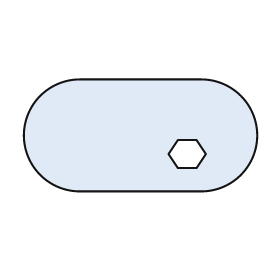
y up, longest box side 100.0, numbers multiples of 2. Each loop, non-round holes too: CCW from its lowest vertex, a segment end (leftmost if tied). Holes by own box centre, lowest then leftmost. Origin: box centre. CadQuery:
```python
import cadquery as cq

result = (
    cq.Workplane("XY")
    .moveTo(-26.0, -24.0)
    .lineTo(26.0, -24.0)
    .threePointArc((50.0, 0.0), (26.0, 24.0))
    .lineTo(-26.0, 24.0)
    .threePointArc((-50.0, 0.0), (-26.0, -24.0))
    .close()
    .moveTo(16.0, -14.0)
    .lineTo(24.0, -14.0)
    .lineTo(28.0, -8.0)
    .lineTo(24.0, -2.0)
    .lineTo(16.0, -2.0)
    .lineTo(12.0, -8.0)
    .close()
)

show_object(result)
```